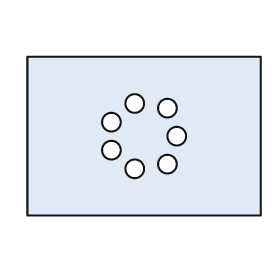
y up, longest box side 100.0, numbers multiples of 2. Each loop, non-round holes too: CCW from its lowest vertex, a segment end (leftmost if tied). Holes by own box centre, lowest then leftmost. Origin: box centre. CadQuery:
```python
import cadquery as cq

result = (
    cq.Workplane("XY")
    .moveTo(-50.0, -34.0)
    .lineTo(50.0, -34.0)
    .lineTo(50.0, 34.0)
    .lineTo(-50.0, 34.0)
    .close()
    .moveTo(-4.0, -14.0)
    .circle(4.0)
    .moveTo(10.0, -12.0)
    .circle(4.0)
    .moveTo(-14.0, -6.0)
    .circle(4.0)
    .moveTo(14.0, 0.0)
    .circle(4.0)
    .moveTo(-14.0, 6.0)
    .circle(4.0)
    .moveTo(10.0, 12.0)
    .circle(4.0)
    .moveTo(-4.0, 14.0)
    .circle(4.0)
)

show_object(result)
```